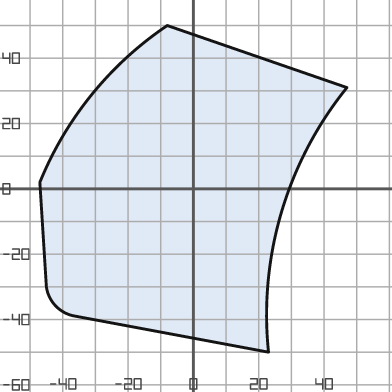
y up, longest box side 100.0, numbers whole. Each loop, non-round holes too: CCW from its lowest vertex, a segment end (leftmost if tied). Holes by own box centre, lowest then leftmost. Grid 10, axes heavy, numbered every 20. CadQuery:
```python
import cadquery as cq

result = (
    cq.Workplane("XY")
    .moveTo(23.0, -50.0)
    .threePointArc((27.0, -7.0), (47.0, 31.0))
    .lineTo(-8.0, 50.0)
    .threePointArc((-31.0, 29.0), (-47.0, 2.0))
    .lineTo(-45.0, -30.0)
    .threePointArc((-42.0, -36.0), (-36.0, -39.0))
    .close()
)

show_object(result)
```